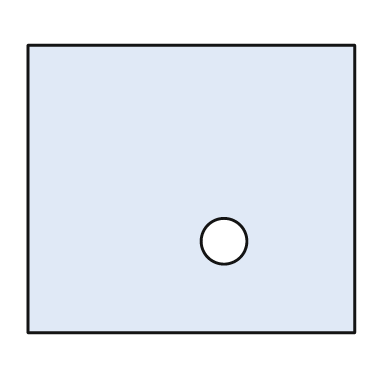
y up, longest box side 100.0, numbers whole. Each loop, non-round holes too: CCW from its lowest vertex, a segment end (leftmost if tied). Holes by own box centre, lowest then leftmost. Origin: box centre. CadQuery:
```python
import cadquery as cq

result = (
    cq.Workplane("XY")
    .moveTo(-50.0, -44.0)
    .lineTo(50.0, -44.0)
    .lineTo(50.0, 44.0)
    .lineTo(-50.0, 44.0)
    .close()
    .moveTo(10.0, -16.0)
    .circle(7.0)
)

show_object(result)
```